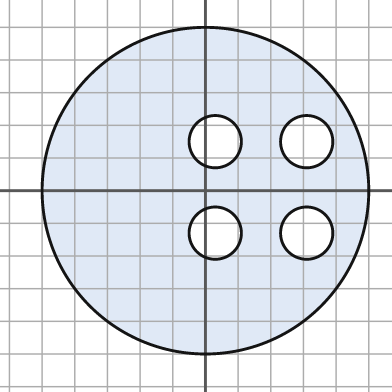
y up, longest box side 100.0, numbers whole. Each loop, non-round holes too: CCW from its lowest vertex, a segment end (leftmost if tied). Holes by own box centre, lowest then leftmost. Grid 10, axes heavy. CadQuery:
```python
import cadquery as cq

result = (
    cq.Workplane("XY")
    .moveTo(0.0, 0.0)
    .circle(50.0)
    .moveTo(3.0, -13.0)
    .circle(8.0)
    .moveTo(31.0, -13.0)
    .circle(8.0)
    .moveTo(3.0, 15.0)
    .circle(8.0)
    .moveTo(31.0, 15.0)
    .circle(8.0)
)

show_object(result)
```